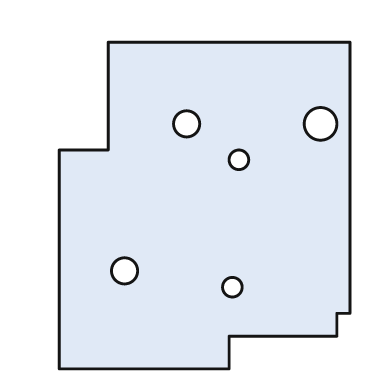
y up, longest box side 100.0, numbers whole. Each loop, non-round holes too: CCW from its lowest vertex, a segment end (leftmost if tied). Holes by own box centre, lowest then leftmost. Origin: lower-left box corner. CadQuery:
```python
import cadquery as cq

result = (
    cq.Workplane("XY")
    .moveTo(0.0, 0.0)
    .lineTo(52.0, 0.0)
    .lineTo(52.0, 10.0)
    .lineTo(85.0, 10.0)
    .lineTo(85.0, 17.0)
    .lineTo(89.0, 17.0)
    .lineTo(89.0, 100.0)
    .lineTo(15.0, 100.0)
    .lineTo(15.0, 67.0)
    .lineTo(0.0, 67.0)
    .close()
    .moveTo(53.0, 25.0)
    .circle(3.0)
    .moveTo(20.0, 30.0)
    .circle(4.0)
    .moveTo(55.0, 64.0)
    .circle(3.0)
    .moveTo(39.0, 75.0)
    .circle(4.0)
    .moveTo(80.0, 75.0)
    .circle(5.0)
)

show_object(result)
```